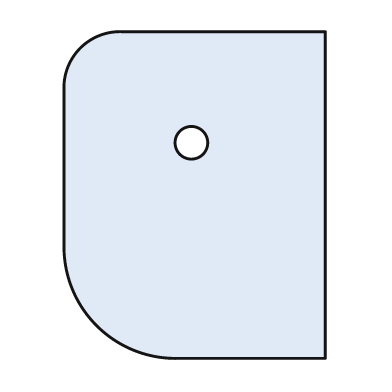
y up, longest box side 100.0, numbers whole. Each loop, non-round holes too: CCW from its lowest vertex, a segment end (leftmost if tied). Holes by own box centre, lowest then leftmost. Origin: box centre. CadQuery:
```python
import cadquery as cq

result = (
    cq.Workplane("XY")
    .moveTo(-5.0, -50.0)
    .lineTo(40.0, -50.0)
    .lineTo(40.0, 50.0)
    .lineTo(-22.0, 50.0)
    .threePointArc((-35.0, 45.0), (-40.0, 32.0))
    .lineTo(-40.0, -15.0)
    .threePointArc((-30.0, -40.0), (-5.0, -50.0))
    .close()
    .moveTo(-1.0, 16.0)
    .circle(5.0)
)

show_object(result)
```